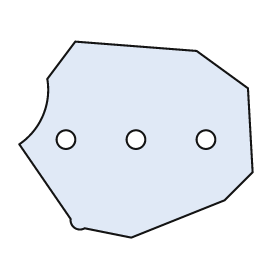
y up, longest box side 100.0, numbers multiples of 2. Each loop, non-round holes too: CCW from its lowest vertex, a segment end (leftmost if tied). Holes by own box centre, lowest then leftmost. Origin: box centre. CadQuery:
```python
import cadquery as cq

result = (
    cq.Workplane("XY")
    .moveTo(-2.0, -42.0)
    .lineTo(38.0, -26.0)
    .lineTo(50.0, -14.0)
    .lineTo(48.0, 22.0)
    .lineTo(26.0, 38.0)
    .lineTo(-26.0, 42.0)
    .lineTo(-38.0, 26.0)
    .threePointArc((-40.0, 10.0), (-50.0, -2.0))
    .lineTo(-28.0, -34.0)
    .threePointArc((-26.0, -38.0), (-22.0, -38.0))
    .close()
    .moveTo(-30.0, 0.0)
    .circle(4.0)
    .moveTo(0.0, 0.0)
    .circle(4.0)
    .moveTo(30.0, 0.0)
    .circle(4.0)
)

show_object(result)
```